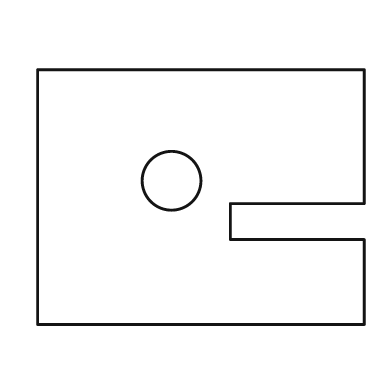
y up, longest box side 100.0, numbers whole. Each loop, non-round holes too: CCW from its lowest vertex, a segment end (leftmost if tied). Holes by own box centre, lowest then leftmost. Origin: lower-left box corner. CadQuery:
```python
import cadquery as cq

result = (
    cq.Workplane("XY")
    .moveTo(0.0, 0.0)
    .lineTo(100.0, 0.0)
    .lineTo(100.0, 26.0)
    .lineTo(59.0, 26.0)
    .lineTo(59.0, 37.0)
    .lineTo(100.0, 37.0)
    .lineTo(100.0, 78.0)
    .lineTo(0.0, 78.0)
    .close()
    .moveTo(41.0, 44.0)
    .circle(9.0)
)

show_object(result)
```